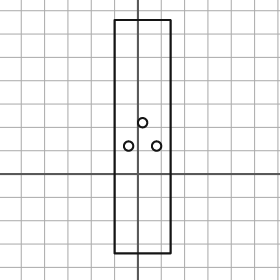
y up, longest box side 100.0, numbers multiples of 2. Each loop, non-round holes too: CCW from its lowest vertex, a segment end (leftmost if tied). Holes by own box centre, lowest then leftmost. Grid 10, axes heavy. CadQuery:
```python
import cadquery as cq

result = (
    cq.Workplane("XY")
    .moveTo(-10.0, -34.0)
    .lineTo(14.0, -34.0)
    .lineTo(14.0, 66.0)
    .lineTo(-10.0, 66.0)
    .close()
    .moveTo(-4.0, 12.0)
    .circle(2.0)
    .moveTo(8.0, 12.0)
    .circle(2.0)
    .moveTo(2.0, 22.0)
    .circle(2.0)
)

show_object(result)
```